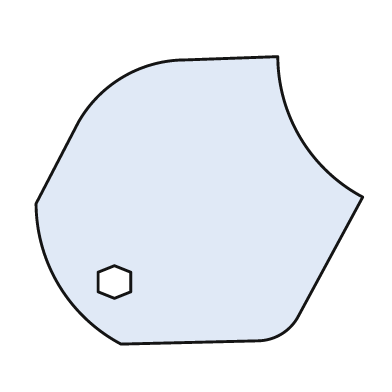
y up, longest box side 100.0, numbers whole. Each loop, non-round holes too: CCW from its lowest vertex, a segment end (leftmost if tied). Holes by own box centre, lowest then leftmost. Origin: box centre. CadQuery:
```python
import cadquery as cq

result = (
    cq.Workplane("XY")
    .moveTo(-24.0, -44.0)
    .lineTo(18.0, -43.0)
    .threePointArc((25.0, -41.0), (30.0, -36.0))
    .lineTo(50.0, 1.0)
    .threePointArc((31.0, 19.0), (24.0, 44.0))
    .lineTo(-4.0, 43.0)
    .threePointArc((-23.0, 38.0), (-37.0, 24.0))
    .lineTo(-50.0, -1.0)
    .threePointArc((-43.0, -26.0), (-24.0, -44.0))
    .close()
    .moveTo(-26.0, -30.0)
    .lineTo(-21.0, -28.0)
    .lineTo(-21.0, -22.0)
    .lineTo(-26.0, -20.0)
    .lineTo(-31.0, -22.0)
    .lineTo(-31.0, -28.0)
    .close()
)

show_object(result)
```